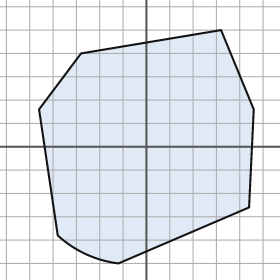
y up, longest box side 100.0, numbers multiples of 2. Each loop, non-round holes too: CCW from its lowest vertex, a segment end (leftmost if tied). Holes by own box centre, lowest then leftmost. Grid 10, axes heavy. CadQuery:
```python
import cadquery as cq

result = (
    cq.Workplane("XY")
    .moveTo(-12.0, -50.0)
    .lineTo(44.0, -26.0)
    .lineTo(46.0, 16.0)
    .lineTo(32.0, 50.0)
    .lineTo(-28.0, 40.0)
    .lineTo(-46.0, 16.0)
    .lineTo(-38.0, -38.0)
    .threePointArc((-26.0, -46.0), (-12.0, -50.0))
    .close()
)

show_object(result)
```